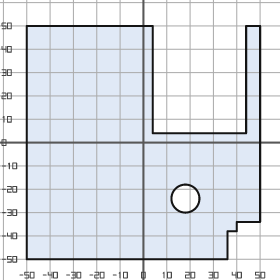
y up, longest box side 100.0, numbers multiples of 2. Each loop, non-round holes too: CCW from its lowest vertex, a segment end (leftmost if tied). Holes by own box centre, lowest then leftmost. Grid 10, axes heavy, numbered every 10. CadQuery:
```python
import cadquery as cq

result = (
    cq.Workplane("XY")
    .moveTo(-50.0, -50.0)
    .lineTo(36.0, -50.0)
    .lineTo(36.0, -38.0)
    .lineTo(40.0, -38.0)
    .lineTo(40.0, -34.0)
    .lineTo(50.0, -34.0)
    .lineTo(50.0, 50.0)
    .lineTo(44.0, 50.0)
    .lineTo(44.0, 4.0)
    .lineTo(4.0, 4.0)
    .lineTo(4.0, 50.0)
    .lineTo(-50.0, 50.0)
    .close()
    .moveTo(18.0, -24.0)
    .circle(6.0)
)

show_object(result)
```